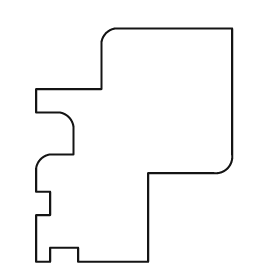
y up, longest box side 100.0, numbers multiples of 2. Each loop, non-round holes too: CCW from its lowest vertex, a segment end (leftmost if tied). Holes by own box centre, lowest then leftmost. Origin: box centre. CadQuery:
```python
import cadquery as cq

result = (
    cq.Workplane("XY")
    .moveTo(-42.0, -50.0)
    .lineTo(-36.0, -50.0)
    .lineTo(-36.0, -44.0)
    .lineTo(-24.0, -44.0)
    .lineTo(-24.0, -50.0)
    .lineTo(6.0, -50.0)
    .lineTo(6.0, -12.0)
    .lineTo(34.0, -12.0)
    .threePointArc((40.0, -10.0), (42.0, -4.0))
    .lineTo(42.0, 50.0)
    .lineTo(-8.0, 50.0)
    .threePointArc((-12.0, 48.0), (-14.0, 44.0))
    .lineTo(-14.0, 24.0)
    .lineTo(-42.0, 24.0)
    .lineTo(-42.0, 14.0)
    .lineTo(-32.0, 14.0)
    .threePointArc((-28.0, 12.0), (-26.0, 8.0))
    .lineTo(-26.0, -4.0)
    .lineTo(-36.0, -4.0)
    .threePointArc((-40.0, -6.0), (-42.0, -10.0))
    .lineTo(-42.0, -20.0)
    .lineTo(-36.0, -20.0)
    .lineTo(-36.0, -30.0)
    .lineTo(-42.0, -30.0)
    .close()
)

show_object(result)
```